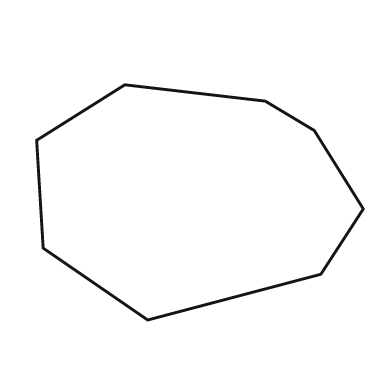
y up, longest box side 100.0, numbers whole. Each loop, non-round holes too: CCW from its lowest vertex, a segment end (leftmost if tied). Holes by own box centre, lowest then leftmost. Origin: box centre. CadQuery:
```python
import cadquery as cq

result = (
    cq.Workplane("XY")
    .moveTo(-16.0, -36.0)
    .lineTo(37.0, -22.0)
    .lineTo(50.0, -2.0)
    .lineTo(35.0, 22.0)
    .lineTo(20.0, 31.0)
    .lineTo(-23.0, 36.0)
    .lineTo(-50.0, 19.0)
    .lineTo(-48.0, -14.0)
    .close()
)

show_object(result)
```